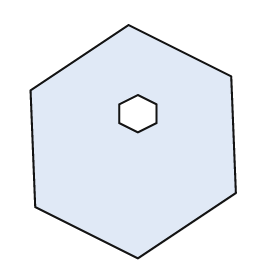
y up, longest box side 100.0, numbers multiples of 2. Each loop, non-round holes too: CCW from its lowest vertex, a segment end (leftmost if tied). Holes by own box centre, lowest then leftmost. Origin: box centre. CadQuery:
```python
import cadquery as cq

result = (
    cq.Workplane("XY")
    .moveTo(2.0, -50.0)
    .lineTo(44.0, -22.0)
    .lineTo(42.0, 28.0)
    .lineTo(-2.0, 50.0)
    .lineTo(-44.0, 22.0)
    .lineTo(-42.0, -28.0)
    .close()
    .moveTo(2.0, 4.0)
    .lineTo(10.0, 8.0)
    .lineTo(10.0, 16.0)
    .lineTo(2.0, 20.0)
    .lineTo(-6.0, 16.0)
    .lineTo(-6.0, 8.0)
    .close()
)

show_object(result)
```